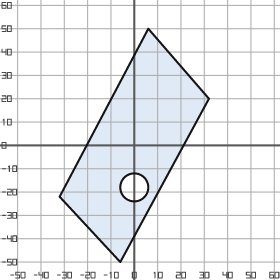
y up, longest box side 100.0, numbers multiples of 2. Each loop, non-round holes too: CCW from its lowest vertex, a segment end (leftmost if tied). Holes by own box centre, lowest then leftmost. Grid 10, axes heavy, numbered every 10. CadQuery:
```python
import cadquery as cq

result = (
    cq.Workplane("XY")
    .moveTo(-6.0, -50.0)
    .lineTo(32.0, 20.0)
    .lineTo(6.0, 50.0)
    .lineTo(-32.0, -22.0)
    .close()
    .moveTo(0.0, -18.0)
    .circle(6.0)
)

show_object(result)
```